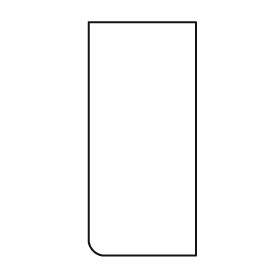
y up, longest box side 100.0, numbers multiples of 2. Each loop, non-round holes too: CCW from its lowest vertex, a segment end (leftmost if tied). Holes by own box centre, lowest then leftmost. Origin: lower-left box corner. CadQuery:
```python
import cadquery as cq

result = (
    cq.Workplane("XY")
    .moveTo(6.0, 0.0)
    .lineTo(46.0, 0.0)
    .lineTo(46.0, 100.0)
    .lineTo(0.0, 100.0)
    .lineTo(0.0, 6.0)
    .threePointArc((2.0, 2.0), (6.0, 0.0))
    .close()
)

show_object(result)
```